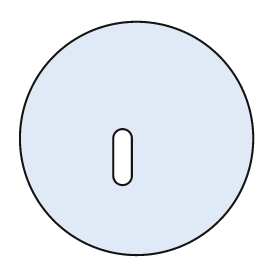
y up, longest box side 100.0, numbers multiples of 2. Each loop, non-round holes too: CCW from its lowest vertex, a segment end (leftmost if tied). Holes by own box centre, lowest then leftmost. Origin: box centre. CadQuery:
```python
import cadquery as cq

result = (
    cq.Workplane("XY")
    .moveTo(0.0, 0.0)
    .circle(50.0)
    .moveTo(-10.0, -16.0)
    .threePointArc((-6.0, -20.0), (-2.0, -16.0))
    .lineTo(-2.0, 0.0)
    .threePointArc((-6.0, 4.0), (-10.0, 0.0))
    .close()
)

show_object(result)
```